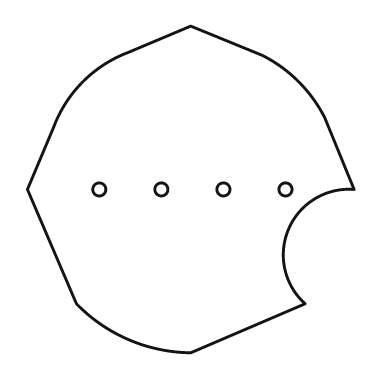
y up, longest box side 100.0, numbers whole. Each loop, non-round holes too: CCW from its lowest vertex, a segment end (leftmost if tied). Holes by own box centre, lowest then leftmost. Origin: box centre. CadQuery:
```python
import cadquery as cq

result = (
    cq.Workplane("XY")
    .moveTo(0.0, -50.0)
    .lineTo(35.0, -35.0)
    .threePointArc((30.0, -12.0), (50.0, 0.0))
    .lineTo(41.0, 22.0)
    .threePointArc((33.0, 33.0), (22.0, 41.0))
    .lineTo(0.0, 50.0)
    .lineTo(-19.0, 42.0)
    .threePointArc((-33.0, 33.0), (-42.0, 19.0))
    .lineTo(-50.0, 0.0)
    .lineTo(-35.0, -35.0)
    .threePointArc((-19.0, -46.0), (0.0, -50.0))
    .close()
    .moveTo(-28.0, 0.0)
    .circle(2.0)
    .moveTo(-9.0, 0.0)
    .circle(2.0)
    .moveTo(10.0, 0.0)
    .circle(2.0)
    .moveTo(29.0, 0.0)
    .circle(2.0)
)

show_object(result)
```